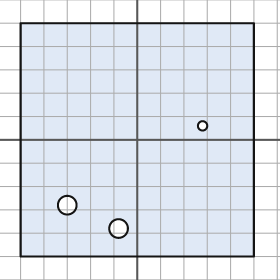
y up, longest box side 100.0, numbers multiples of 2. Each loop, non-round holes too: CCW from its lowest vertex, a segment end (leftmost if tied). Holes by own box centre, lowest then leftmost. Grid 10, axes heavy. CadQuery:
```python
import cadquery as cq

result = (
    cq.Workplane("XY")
    .moveTo(-50.0, -50.0)
    .lineTo(50.0, -50.0)
    .lineTo(50.0, 50.0)
    .lineTo(-50.0, 50.0)
    .close()
    .moveTo(-8.0, -38.0)
    .circle(4.0)
    .moveTo(-30.0, -28.0)
    .circle(4.0)
    .moveTo(28.0, 6.0)
    .circle(2.0)
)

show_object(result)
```